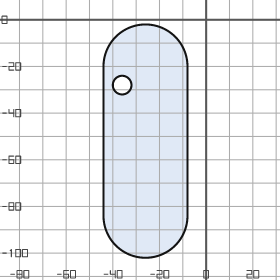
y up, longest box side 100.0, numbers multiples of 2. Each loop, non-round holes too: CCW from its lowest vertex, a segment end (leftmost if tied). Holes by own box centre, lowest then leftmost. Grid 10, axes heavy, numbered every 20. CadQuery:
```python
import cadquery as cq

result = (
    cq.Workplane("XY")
    .moveTo(-44.0, -84.0)
    .threePointArc((-26.0, -102.0), (-8.0, -84.0))
    .lineTo(-8.0, -20.0)
    .threePointArc((-26.0, -2.0), (-44.0, -20.0))
    .close()
    .moveTo(-36.0, -28.0)
    .circle(4.0)
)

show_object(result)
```